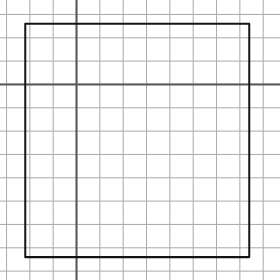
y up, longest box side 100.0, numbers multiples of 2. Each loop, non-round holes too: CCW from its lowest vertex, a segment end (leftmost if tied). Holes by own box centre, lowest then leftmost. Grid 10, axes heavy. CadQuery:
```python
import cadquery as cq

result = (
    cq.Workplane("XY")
    .moveTo(-22.0, -74.0)
    .lineTo(74.0, -74.0)
    .lineTo(74.0, 26.0)
    .lineTo(-22.0, 26.0)
    .close()
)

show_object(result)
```